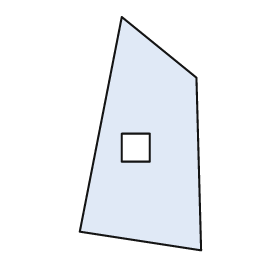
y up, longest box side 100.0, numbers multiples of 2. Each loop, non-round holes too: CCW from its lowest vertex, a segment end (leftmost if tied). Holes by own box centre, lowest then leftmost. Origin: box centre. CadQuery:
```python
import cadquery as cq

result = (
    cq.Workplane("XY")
    .moveTo(26.0, -50.0)
    .lineTo(24.0, 24.0)
    .lineTo(-8.0, 50.0)
    .lineTo(-26.0, -42.0)
    .close()
    .moveTo(-8.0, -12.0)
    .lineTo(4.0, -12.0)
    .lineTo(4.0, 0.0)
    .lineTo(-8.0, 0.0)
    .close()
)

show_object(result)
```